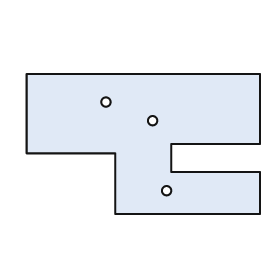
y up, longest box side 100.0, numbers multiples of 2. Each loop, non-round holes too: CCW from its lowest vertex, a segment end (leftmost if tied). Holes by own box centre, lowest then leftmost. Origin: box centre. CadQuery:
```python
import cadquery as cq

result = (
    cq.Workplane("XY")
    .moveTo(-12.0, -30.0)
    .lineTo(50.0, -30.0)
    .lineTo(50.0, -12.0)
    .lineTo(12.0, -12.0)
    .lineTo(12.0, 0.0)
    .lineTo(50.0, 0.0)
    .lineTo(50.0, 30.0)
    .lineTo(-50.0, 30.0)
    .lineTo(-50.0, -4.0)
    .lineTo(-12.0, -4.0)
    .close()
    .moveTo(10.0, -20.0)
    .circle(2.0)
    .moveTo(4.0, 10.0)
    .circle(2.0)
    .moveTo(-16.0, 18.0)
    .circle(2.0)
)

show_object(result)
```